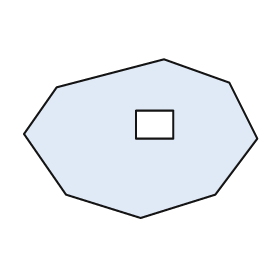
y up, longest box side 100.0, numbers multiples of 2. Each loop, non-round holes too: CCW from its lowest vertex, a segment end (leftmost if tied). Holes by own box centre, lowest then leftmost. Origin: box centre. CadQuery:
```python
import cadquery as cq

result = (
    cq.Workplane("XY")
    .moveTo(0.0, -34.0)
    .lineTo(32.0, -24.0)
    .lineTo(50.0, 0.0)
    .lineTo(38.0, 24.0)
    .lineTo(10.0, 34.0)
    .lineTo(-36.0, 22.0)
    .lineTo(-50.0, 2.0)
    .lineTo(-32.0, -24.0)
    .close()
    .moveTo(-2.0, 0.0)
    .lineTo(14.0, 0.0)
    .lineTo(14.0, 12.0)
    .lineTo(-2.0, 12.0)
    .close()
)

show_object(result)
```